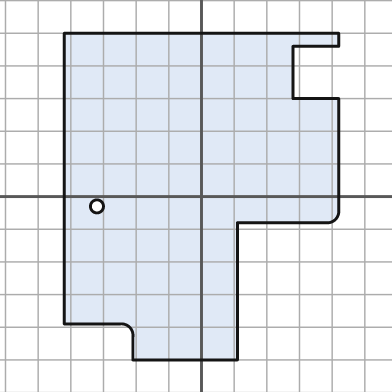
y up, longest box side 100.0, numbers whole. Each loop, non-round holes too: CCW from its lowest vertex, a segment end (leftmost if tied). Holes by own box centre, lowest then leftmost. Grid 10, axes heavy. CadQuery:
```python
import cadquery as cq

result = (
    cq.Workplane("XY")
    .moveTo(-21.0, -50.0)
    .lineTo(11.0, -50.0)
    .lineTo(11.0, -8.0)
    .lineTo(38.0, -8.0)
    .threePointArc((41.0, -7.0), (42.0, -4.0))
    .lineTo(42.0, 30.0)
    .lineTo(28.0, 30.0)
    .lineTo(28.0, 46.0)
    .lineTo(42.0, 46.0)
    .lineTo(42.0, 50.0)
    .lineTo(-42.0, 50.0)
    .lineTo(-42.0, -39.0)
    .lineTo(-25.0, -39.0)
    .threePointArc((-22.0, -40.0), (-21.0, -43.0))
    .close()
    .moveTo(-32.0, -3.0)
    .circle(2.0)
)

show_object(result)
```